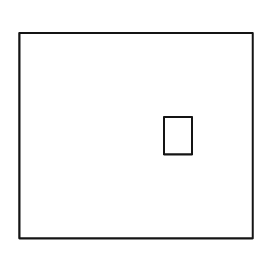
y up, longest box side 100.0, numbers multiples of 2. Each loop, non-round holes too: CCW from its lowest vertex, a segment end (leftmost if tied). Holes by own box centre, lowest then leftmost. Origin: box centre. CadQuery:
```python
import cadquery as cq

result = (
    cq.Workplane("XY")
    .moveTo(-50.0, -44.0)
    .lineTo(50.0, -44.0)
    .lineTo(50.0, 44.0)
    .lineTo(-50.0, 44.0)
    .close()
    .moveTo(12.0, -8.0)
    .lineTo(24.0, -8.0)
    .lineTo(24.0, 8.0)
    .lineTo(12.0, 8.0)
    .close()
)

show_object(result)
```